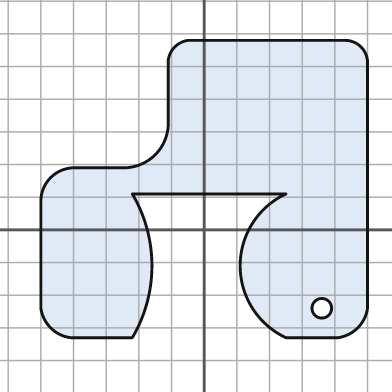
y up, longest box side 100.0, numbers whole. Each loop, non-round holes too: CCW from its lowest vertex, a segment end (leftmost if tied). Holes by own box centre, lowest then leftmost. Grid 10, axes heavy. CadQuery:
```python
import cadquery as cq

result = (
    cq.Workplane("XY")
    .moveTo(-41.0, -33.0)
    .lineTo(-22.0, -33.0)
    .threePointArc((-16.0, -11.0), (-22.0, 11.0))
    .lineTo(25.0, 11.0)
    .threePointArc((11.0, -11.0), (25.0, -33.0))
    .lineTo(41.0, -33.0)
    .threePointArc((47.0, -30.0), (50.0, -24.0))
    .lineTo(50.0, 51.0)
    .threePointArc((48.0, 56.0), (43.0, 58.0))
    .lineTo(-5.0, 58.0)
    .threePointArc((-9.0, 56.0), (-11.0, 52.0))
    .lineTo(-11.0, 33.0)
    .threePointArc((-15.0, 23.0), (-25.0, 19.0))
    .lineTo(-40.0, 19.0)
    .threePointArc((-47.0, 16.0), (-50.0, 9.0))
    .lineTo(-50.0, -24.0)
    .threePointArc((-47.0, -30.0), (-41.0, -33.0))
    .close()
    .moveTo(36.0, -24.0)
    .circle(3.0)
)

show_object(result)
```